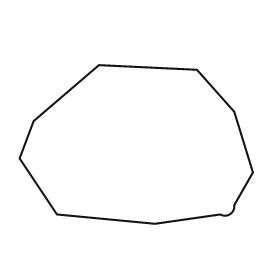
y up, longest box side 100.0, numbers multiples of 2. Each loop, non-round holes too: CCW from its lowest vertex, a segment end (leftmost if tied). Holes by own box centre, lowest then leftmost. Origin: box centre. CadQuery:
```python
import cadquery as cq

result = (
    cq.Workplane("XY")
    .moveTo(8.0, -34.0)
    .lineTo(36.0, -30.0)
    .threePointArc((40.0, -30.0), (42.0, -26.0))
    .lineTo(50.0, -12.0)
    .lineTo(42.0, 14.0)
    .lineTo(26.0, 32.0)
    .lineTo(-16.0, 34.0)
    .lineTo(-44.0, 10.0)
    .lineTo(-50.0, -6.0)
    .lineTo(-34.0, -30.0)
    .close()
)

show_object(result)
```